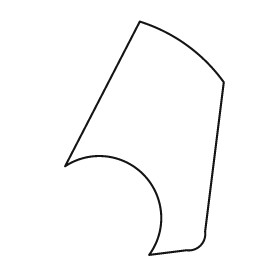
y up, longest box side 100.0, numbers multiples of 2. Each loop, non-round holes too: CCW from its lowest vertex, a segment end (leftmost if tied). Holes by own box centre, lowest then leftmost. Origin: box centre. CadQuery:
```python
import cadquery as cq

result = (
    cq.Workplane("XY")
    .moveTo(2.0, -50.0)
    .lineTo(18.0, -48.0)
    .threePointArc((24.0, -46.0), (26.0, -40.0))
    .lineTo(34.0, 24.0)
    .threePointArc((18.0, 40.0), (-2.0, 50.0))
    .lineTo(-34.0, -12.0)
    .threePointArc((0.0, -16.0), (2.0, -50.0))
    .close()
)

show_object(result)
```